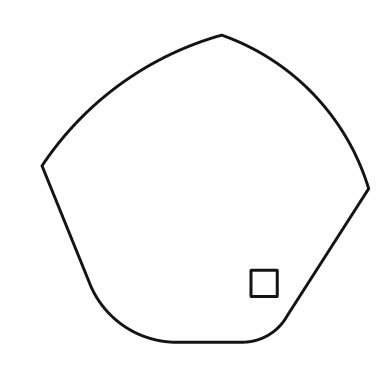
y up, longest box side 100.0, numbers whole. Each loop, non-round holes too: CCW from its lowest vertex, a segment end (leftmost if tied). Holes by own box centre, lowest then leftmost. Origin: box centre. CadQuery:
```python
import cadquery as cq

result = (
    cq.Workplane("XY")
    .moveTo(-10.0, -47.0)
    .lineTo(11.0, -47.0)
    .threePointArc((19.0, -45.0), (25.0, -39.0))
    .lineTo(50.0, 0.0)
    .threePointArc((33.0, 29.0), (5.0, 47.0))
    .threePointArc((-26.0, 32.0), (-50.0, 7.0))
    .lineTo(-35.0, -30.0)
    .threePointArc((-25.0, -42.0), (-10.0, -47.0))
    .close()
    .moveTo(14.0, -33.0)
    .lineTo(22.0, -33.0)
    .lineTo(22.0, -25.0)
    .lineTo(14.0, -25.0)
    .close()
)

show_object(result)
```